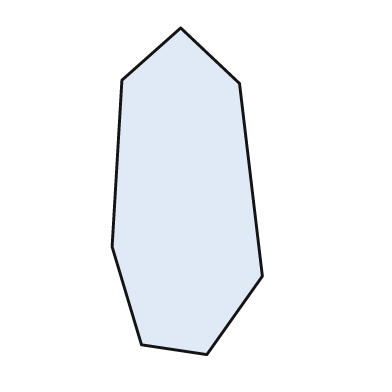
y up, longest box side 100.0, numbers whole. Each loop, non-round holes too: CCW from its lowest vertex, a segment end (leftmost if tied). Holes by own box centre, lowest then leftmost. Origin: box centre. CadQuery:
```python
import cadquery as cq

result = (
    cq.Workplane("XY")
    .moveTo(6.0, -50.0)
    .lineTo(23.0, -26.0)
    .lineTo(16.0, 33.0)
    .lineTo(-2.0, 50.0)
    .lineTo(-20.0, 34.0)
    .lineTo(-23.0, -17.0)
    .lineTo(-14.0, -47.0)
    .close()
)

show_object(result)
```